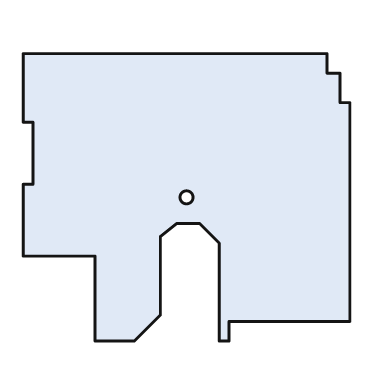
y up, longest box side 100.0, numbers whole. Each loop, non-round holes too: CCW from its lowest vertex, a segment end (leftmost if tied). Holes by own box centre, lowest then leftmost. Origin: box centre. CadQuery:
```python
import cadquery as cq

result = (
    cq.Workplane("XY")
    .moveTo(-28.0, -44.0)
    .lineTo(-16.0, -44.0)
    .lineTo(-8.0, -36.0)
    .lineTo(-8.0, -12.0)
    .lineTo(-3.0, -8.0)
    .lineTo(4.0, -8.0)
    .lineTo(10.0, -14.0)
    .lineTo(10.0, -44.0)
    .lineTo(13.0, -44.0)
    .lineTo(13.0, -38.0)
    .lineTo(50.0, -38.0)
    .lineTo(50.0, 29.0)
    .lineTo(47.0, 29.0)
    .lineTo(47.0, 38.0)
    .lineTo(43.0, 38.0)
    .lineTo(43.0, 44.0)
    .lineTo(-50.0, 44.0)
    .lineTo(-50.0, 23.0)
    .lineTo(-47.0, 23.0)
    .lineTo(-47.0, 4.0)
    .lineTo(-50.0, 4.0)
    .lineTo(-50.0, -18.0)
    .lineTo(-28.0, -18.0)
    .close()
    .moveTo(0.0, 0.0)
    .circle(2.0)
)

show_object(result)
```